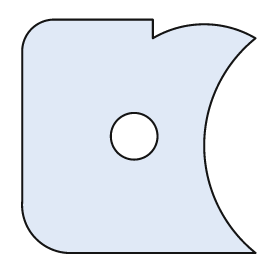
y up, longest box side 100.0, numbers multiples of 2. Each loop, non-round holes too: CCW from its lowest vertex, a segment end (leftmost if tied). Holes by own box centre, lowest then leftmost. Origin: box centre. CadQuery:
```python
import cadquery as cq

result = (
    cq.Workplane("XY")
    .moveTo(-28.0, -50.0)
    .lineTo(50.0, -50.0)
    .threePointArc((28.0, -4.0), (50.0, 42.0))
    .threePointArc((28.0, 48.0), (6.0, 42.0))
    .lineTo(6.0, 50.0)
    .lineTo(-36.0, 50.0)
    .threePointArc((-46.0, 46.0), (-50.0, 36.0))
    .lineTo(-50.0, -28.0)
    .threePointArc((-44.0, -44.0), (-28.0, -50.0))
    .close()
    .moveTo(-2.0, 0.0)
    .circle(10.0)
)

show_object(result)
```